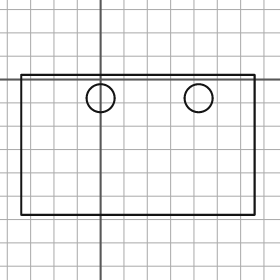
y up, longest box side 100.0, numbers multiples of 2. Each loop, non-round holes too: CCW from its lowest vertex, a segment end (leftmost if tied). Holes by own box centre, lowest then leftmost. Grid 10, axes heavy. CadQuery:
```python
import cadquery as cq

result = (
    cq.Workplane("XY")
    .moveTo(-34.0, -58.0)
    .lineTo(66.0, -58.0)
    .lineTo(66.0, 2.0)
    .lineTo(-34.0, 2.0)
    .close()
    .moveTo(0.0, -8.0)
    .circle(6.0)
    .moveTo(42.0, -8.0)
    .circle(6.0)
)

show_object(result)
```